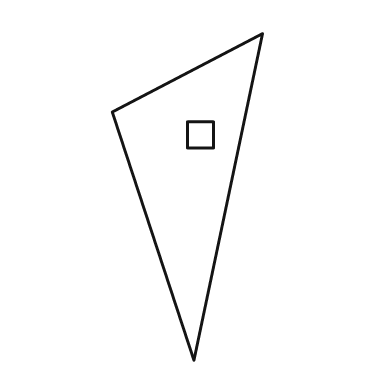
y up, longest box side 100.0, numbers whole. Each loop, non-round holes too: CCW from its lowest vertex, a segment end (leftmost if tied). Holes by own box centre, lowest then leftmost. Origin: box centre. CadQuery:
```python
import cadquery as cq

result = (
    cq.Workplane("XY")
    .moveTo(2.0, -50.0)
    .lineTo(23.0, 50.0)
    .lineTo(-23.0, 26.0)
    .close()
    .moveTo(0.0, 15.0)
    .lineTo(8.0, 15.0)
    .lineTo(8.0, 23.0)
    .lineTo(0.0, 23.0)
    .close()
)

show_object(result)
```